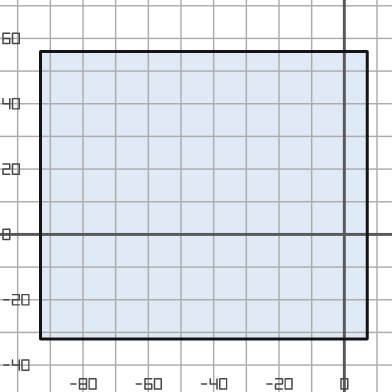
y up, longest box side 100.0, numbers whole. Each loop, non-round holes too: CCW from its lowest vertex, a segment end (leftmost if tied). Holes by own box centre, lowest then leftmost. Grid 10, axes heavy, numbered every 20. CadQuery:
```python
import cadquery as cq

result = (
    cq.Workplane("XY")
    .moveTo(-93.0, -32.0)
    .lineTo(7.0, -32.0)
    .lineTo(7.0, 56.0)
    .lineTo(-93.0, 56.0)
    .close()
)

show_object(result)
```